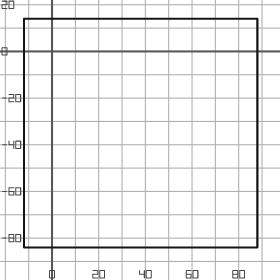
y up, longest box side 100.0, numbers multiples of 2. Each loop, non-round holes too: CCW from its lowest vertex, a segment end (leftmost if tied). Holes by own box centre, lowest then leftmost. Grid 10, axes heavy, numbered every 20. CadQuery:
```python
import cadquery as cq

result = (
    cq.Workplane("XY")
    .moveTo(-12.0, -84.0)
    .lineTo(88.0, -84.0)
    .lineTo(88.0, 14.0)
    .lineTo(-12.0, 14.0)
    .close()
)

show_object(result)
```